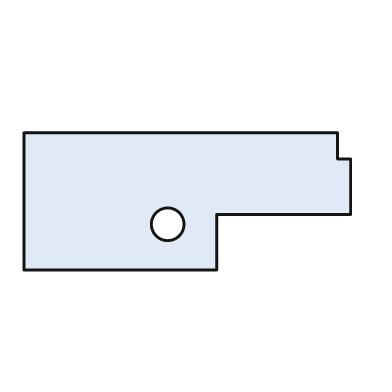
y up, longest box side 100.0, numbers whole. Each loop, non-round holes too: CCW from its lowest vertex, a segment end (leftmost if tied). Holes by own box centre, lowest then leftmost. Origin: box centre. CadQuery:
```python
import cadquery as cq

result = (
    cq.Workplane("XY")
    .moveTo(-50.0, -21.0)
    .lineTo(9.0, -21.0)
    .lineTo(9.0, -4.0)
    .lineTo(50.0, -4.0)
    .lineTo(50.0, 13.0)
    .lineTo(46.0, 13.0)
    .lineTo(46.0, 21.0)
    .lineTo(-50.0, 21.0)
    .close()
    .moveTo(-6.0, -7.0)
    .circle(5.0)
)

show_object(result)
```